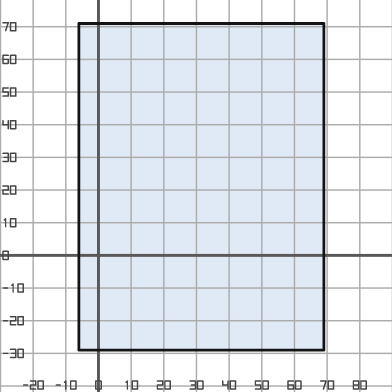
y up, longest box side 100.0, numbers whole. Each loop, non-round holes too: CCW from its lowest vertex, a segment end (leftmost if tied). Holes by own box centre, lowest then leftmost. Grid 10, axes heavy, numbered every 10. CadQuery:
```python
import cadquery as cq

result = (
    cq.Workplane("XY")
    .moveTo(-6.0, -29.0)
    .lineTo(69.0, -29.0)
    .lineTo(69.0, 71.0)
    .lineTo(-6.0, 71.0)
    .close()
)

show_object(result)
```